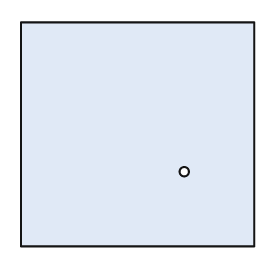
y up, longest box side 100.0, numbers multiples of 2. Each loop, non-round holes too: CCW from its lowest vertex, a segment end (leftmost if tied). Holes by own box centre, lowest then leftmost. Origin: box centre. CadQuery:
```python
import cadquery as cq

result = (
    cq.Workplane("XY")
    .moveTo(-50.0, -48.0)
    .lineTo(50.0, -48.0)
    .lineTo(50.0, 48.0)
    .lineTo(-50.0, 48.0)
    .close()
    .moveTo(20.0, -16.0)
    .circle(2.0)
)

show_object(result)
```